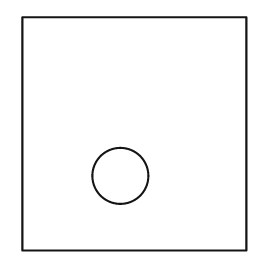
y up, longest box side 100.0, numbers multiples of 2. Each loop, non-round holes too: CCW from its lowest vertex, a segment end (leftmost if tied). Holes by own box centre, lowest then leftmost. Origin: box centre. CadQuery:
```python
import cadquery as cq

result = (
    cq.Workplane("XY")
    .moveTo(-48.0, -50.0)
    .lineTo(48.0, -50.0)
    .lineTo(48.0, 50.0)
    .lineTo(-48.0, 50.0)
    .close()
    .moveTo(-6.0, -18.0)
    .circle(12.0)
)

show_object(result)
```